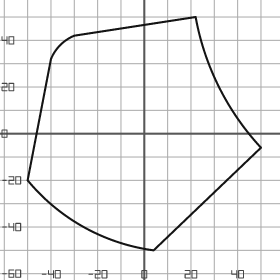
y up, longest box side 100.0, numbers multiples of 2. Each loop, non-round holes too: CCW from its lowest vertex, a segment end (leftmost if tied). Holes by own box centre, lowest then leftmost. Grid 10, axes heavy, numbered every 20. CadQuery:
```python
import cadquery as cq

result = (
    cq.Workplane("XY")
    .moveTo(4.0, -50.0)
    .lineTo(50.0, -6.0)
    .threePointArc((32.0, 20.0), (22.0, 50.0))
    .lineTo(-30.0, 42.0)
    .threePointArc((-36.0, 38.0), (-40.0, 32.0))
    .lineTo(-50.0, -20.0)
    .threePointArc((-26.0, -40.0), (4.0, -50.0))
    .close()
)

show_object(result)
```